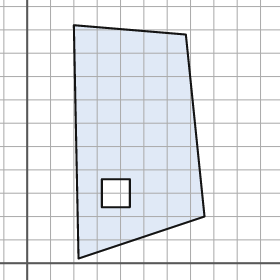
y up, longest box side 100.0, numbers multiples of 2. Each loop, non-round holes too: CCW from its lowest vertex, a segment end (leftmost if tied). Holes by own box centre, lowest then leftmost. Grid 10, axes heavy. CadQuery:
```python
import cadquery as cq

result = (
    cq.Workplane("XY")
    .moveTo(22.0, 2.0)
    .lineTo(76.0, 20.0)
    .lineTo(68.0, 98.0)
    .lineTo(20.0, 102.0)
    .close()
    .moveTo(32.0, 24.0)
    .lineTo(44.0, 24.0)
    .lineTo(44.0, 36.0)
    .lineTo(32.0, 36.0)
    .close()
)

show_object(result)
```